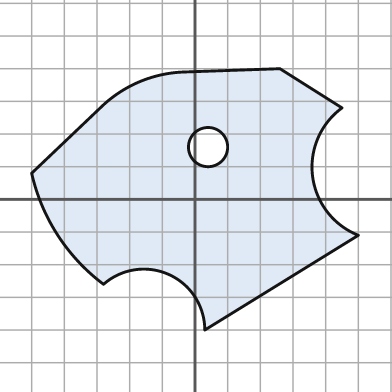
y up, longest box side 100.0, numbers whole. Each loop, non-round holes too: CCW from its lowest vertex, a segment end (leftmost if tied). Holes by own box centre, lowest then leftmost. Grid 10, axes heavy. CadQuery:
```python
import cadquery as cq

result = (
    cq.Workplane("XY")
    .moveTo(3.0, -40.0)
    .lineTo(50.0, -11.0)
    .threePointArc((36.0, 7.0), (45.0, 28.0))
    .lineTo(26.0, 40.0)
    .lineTo(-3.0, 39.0)
    .threePointArc((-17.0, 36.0), (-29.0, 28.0))
    .lineTo(-50.0, 8.0)
    .threePointArc((-42.0, -11.0), (-28.0, -26.0))
    .threePointArc((-8.0, -23.0), (3.0, -40.0))
    .close()
    .moveTo(4.0, 16.0)
    .circle(6.0)
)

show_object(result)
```